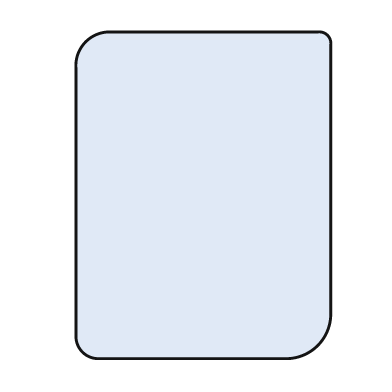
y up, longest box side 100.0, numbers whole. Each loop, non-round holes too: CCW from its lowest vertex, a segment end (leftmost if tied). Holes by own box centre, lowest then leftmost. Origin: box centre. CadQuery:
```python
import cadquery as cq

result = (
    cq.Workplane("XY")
    .moveTo(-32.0, -50.0)
    .lineTo(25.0, -50.0)
    .threePointArc((35.0, -46.0), (39.0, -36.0))
    .lineTo(39.0, 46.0)
    .threePointArc((38.0, 49.0), (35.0, 50.0))
    .lineTo(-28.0, 50.0)
    .threePointArc((-36.0, 47.0), (-39.0, 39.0))
    .lineTo(-39.0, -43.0)
    .threePointArc((-37.0, -48.0), (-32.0, -50.0))
    .close()
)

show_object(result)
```